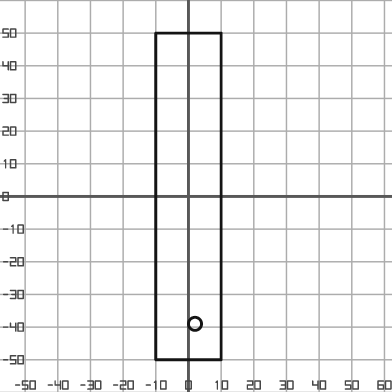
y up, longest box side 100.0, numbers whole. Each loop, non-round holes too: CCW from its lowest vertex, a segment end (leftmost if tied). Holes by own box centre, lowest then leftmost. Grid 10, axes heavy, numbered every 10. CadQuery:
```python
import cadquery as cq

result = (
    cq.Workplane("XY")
    .moveTo(-10.0, -50.0)
    .lineTo(10.0, -50.0)
    .lineTo(10.0, 50.0)
    .lineTo(-10.0, 50.0)
    .close()
    .moveTo(2.0, -39.0)
    .circle(2.0)
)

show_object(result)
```